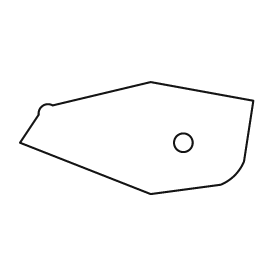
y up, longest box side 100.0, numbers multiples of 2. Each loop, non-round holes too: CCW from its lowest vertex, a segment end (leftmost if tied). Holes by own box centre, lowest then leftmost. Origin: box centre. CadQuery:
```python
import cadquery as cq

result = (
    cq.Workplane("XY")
    .moveTo(6.0, -24.0)
    .lineTo(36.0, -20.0)
    .threePointArc((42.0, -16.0), (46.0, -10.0))
    .lineTo(50.0, 16.0)
    .lineTo(6.0, 24.0)
    .lineTo(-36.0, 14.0)
    .threePointArc((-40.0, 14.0), (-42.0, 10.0))
    .lineTo(-50.0, -2.0)
    .close()
    .moveTo(20.0, -2.0)
    .circle(4.0)
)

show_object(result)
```